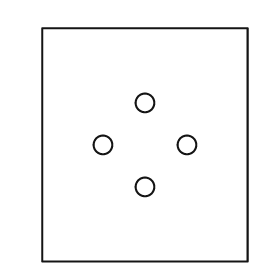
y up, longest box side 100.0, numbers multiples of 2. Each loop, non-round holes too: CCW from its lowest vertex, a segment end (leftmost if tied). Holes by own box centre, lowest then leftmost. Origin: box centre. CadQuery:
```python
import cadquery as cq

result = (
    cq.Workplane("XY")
    .moveTo(-44.0, -50.0)
    .lineTo(44.0, -50.0)
    .lineTo(44.0, 50.0)
    .lineTo(-44.0, 50.0)
    .close()
    .moveTo(0.0, -18.0)
    .circle(4.0)
    .moveTo(-18.0, 0.0)
    .circle(4.0)
    .moveTo(18.0, 0.0)
    .circle(4.0)
    .moveTo(0.0, 18.0)
    .circle(4.0)
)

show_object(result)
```